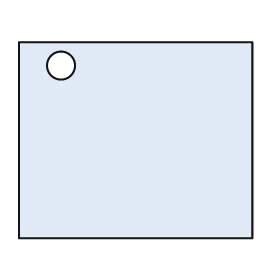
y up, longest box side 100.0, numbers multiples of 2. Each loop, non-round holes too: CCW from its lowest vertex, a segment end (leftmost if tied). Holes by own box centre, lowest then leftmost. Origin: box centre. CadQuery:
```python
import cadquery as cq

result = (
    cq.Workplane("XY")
    .moveTo(-50.0, -42.0)
    .lineTo(50.0, -42.0)
    .lineTo(50.0, 42.0)
    .lineTo(-50.0, 42.0)
    .close()
    .moveTo(-32.0, 32.0)
    .circle(6.0)
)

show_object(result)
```